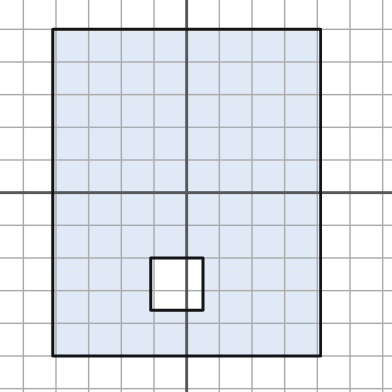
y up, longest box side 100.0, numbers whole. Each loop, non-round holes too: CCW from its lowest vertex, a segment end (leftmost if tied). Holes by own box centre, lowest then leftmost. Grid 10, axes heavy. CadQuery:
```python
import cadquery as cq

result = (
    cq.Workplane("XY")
    .moveTo(-41.0, -50.0)
    .lineTo(41.0, -50.0)
    .lineTo(41.0, 50.0)
    .lineTo(-41.0, 50.0)
    .close()
    .moveTo(-11.0, -36.0)
    .lineTo(5.0, -36.0)
    .lineTo(5.0, -20.0)
    .lineTo(-11.0, -20.0)
    .close()
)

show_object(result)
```